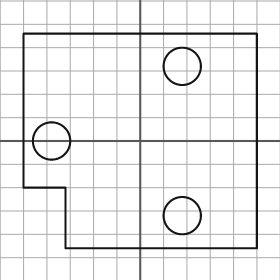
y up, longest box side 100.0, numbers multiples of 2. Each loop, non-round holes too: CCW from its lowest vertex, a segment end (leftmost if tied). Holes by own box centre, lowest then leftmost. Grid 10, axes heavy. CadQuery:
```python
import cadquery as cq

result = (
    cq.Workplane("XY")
    .moveTo(-32.0, -46.0)
    .lineTo(50.0, -46.0)
    .lineTo(50.0, 46.0)
    .lineTo(-50.0, 46.0)
    .lineTo(-50.0, -20.0)
    .lineTo(-32.0, -20.0)
    .close()
    .moveTo(18.0, -32.0)
    .circle(8.0)
    .moveTo(-38.0, 0.0)
    .circle(8.0)
    .moveTo(18.0, 32.0)
    .circle(8.0)
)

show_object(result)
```